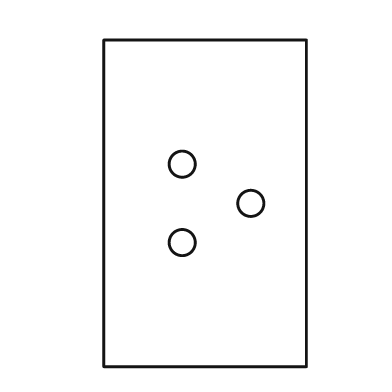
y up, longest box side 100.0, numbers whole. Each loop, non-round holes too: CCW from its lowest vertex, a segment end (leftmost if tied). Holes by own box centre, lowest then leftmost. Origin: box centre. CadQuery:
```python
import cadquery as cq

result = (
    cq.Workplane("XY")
    .moveTo(-31.0, -50.0)
    .lineTo(31.0, -50.0)
    .lineTo(31.0, 50.0)
    .lineTo(-31.0, 50.0)
    .close()
    .moveTo(-7.0, -12.0)
    .circle(4.0)
    .moveTo(14.0, 0.0)
    .circle(4.0)
    .moveTo(-7.0, 12.0)
    .circle(4.0)
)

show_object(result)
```